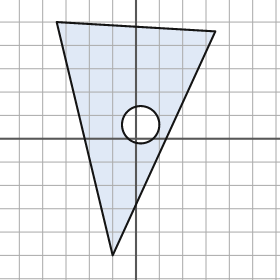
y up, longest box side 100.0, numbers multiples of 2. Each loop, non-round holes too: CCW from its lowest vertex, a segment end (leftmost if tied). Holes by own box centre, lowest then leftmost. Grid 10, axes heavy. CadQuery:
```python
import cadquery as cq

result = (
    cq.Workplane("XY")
    .moveTo(-10.0, -50.0)
    .lineTo(34.0, 46.0)
    .lineTo(-34.0, 50.0)
    .close()
    .moveTo(2.0, 6.0)
    .circle(8.0)
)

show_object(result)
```